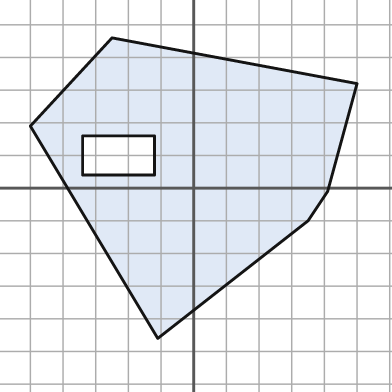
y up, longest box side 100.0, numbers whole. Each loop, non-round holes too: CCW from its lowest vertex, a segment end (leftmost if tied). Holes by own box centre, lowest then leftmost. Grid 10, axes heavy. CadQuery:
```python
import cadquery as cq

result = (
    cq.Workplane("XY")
    .moveTo(-11.0, -46.0)
    .lineTo(35.0, -10.0)
    .lineTo(41.0, -1.0)
    .lineTo(50.0, 32.0)
    .lineTo(-25.0, 46.0)
    .lineTo(-50.0, 19.0)
    .close()
    .moveTo(-34.0, 4.0)
    .lineTo(-12.0, 4.0)
    .lineTo(-12.0, 16.0)
    .lineTo(-34.0, 16.0)
    .close()
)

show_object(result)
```